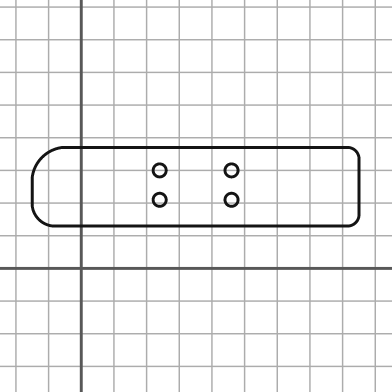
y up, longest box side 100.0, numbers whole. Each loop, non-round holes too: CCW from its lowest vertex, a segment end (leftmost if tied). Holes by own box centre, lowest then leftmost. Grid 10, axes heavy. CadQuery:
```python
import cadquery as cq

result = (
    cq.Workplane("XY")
    .moveTo(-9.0, 13.0)
    .lineTo(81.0, 13.0)
    .threePointArc((84.0, 14.0), (85.0, 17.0))
    .lineTo(85.0, 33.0)
    .threePointArc((84.0, 36.0), (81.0, 37.0))
    .lineTo(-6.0, 37.0)
    .threePointArc((-12.0, 34.0), (-15.0, 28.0))
    .lineTo(-15.0, 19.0)
    .threePointArc((-13.0, 15.0), (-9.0, 13.0))
    .close()
    .moveTo(24.0, 21.0)
    .circle(2.0)
    .moveTo(46.0, 21.0)
    .circle(2.0)
    .moveTo(24.0, 30.0)
    .circle(2.0)
    .moveTo(46.0, 30.0)
    .circle(2.0)
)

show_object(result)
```